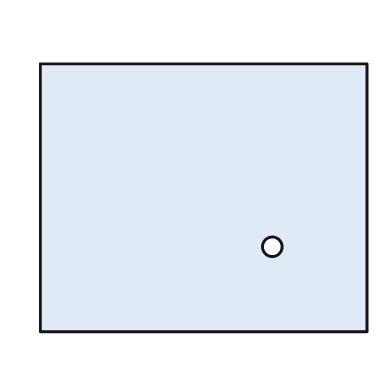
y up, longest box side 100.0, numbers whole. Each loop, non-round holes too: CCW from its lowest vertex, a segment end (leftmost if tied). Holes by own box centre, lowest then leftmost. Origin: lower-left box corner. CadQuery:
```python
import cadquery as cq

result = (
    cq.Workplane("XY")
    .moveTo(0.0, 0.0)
    .lineTo(100.0, 0.0)
    .lineTo(100.0, 82.0)
    .lineTo(0.0, 82.0)
    .close()
    .moveTo(71.0, 26.0)
    .circle(3.0)
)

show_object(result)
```